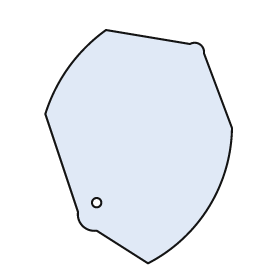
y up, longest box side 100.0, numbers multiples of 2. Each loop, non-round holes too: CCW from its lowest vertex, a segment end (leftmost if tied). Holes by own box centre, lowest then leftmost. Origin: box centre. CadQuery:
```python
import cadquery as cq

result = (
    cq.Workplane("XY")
    .moveTo(4.0, -50.0)
    .threePointArc((30.0, -26.0), (40.0, 8.0))
    .lineTo(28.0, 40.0)
    .threePointArc((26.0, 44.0), (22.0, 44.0))
    .lineTo(-14.0, 50.0)
    .threePointArc((-30.0, 34.0), (-40.0, 14.0))
    .lineTo(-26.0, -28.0)
    .threePointArc((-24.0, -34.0), (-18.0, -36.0))
    .close()
    .moveTo(-18.0, -24.0)
    .circle(2.0)
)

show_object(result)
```